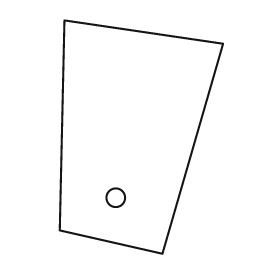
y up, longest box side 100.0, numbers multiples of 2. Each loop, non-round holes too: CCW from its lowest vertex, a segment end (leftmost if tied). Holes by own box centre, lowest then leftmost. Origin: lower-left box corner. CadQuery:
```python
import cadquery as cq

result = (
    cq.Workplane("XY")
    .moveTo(44.0, 0.0)
    .lineTo(70.0, 90.0)
    .lineTo(2.0, 100.0)
    .lineTo(0.0, 10.0)
    .close()
    .moveTo(24.0, 24.0)
    .circle(4.0)
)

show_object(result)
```